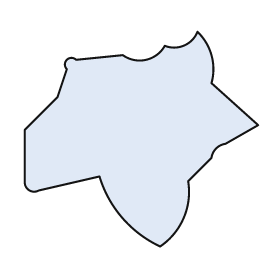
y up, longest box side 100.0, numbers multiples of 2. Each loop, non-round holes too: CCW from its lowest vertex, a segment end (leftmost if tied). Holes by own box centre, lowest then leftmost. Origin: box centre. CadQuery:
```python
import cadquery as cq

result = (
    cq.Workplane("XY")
    .moveTo(8.0, -46.0)
    .threePointArc((18.0, -34.0), (20.0, -18.0))
    .lineTo(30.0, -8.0)
    .threePointArc((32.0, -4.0), (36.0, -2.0))
    .lineTo(50.0, 6.0)
    .lineTo(30.0, 24.0)
    .threePointArc((30.0, 36.0), (24.0, 46.0))
    .threePointArc((18.0, 40.0), (10.0, 40.0))
    .threePointArc((2.0, 34.0), (-8.0, 36.0))
    .lineTo(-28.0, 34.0)
    .threePointArc((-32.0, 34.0), (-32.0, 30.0))
    .lineTo(-36.0, 18.0)
    .lineTo(-50.0, 4.0)
    .lineTo(-50.0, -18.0)
    .threePointArc((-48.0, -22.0), (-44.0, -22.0))
    .lineTo(-18.0, -16.0)
    .threePointArc((-8.0, -34.0), (8.0, -46.0))
    .close()
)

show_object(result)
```